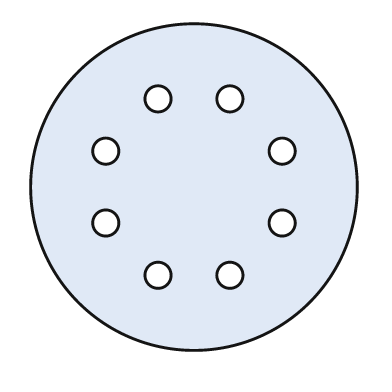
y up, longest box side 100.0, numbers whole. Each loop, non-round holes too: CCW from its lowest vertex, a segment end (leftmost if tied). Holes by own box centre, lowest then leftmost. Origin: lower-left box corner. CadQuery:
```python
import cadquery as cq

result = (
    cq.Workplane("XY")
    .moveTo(50.0, 50.0)
    .circle(50.0)
    .moveTo(39.0, 23.0)
    .circle(4.0)
    .moveTo(61.0, 23.0)
    .circle(4.0)
    .moveTo(23.0, 39.0)
    .circle(4.0)
    .moveTo(77.0, 39.0)
    .circle(4.0)
    .moveTo(23.0, 61.0)
    .circle(4.0)
    .moveTo(77.0, 61.0)
    .circle(4.0)
    .moveTo(39.0, 77.0)
    .circle(4.0)
    .moveTo(61.0, 77.0)
    .circle(4.0)
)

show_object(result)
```